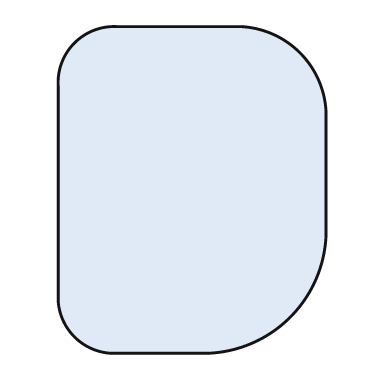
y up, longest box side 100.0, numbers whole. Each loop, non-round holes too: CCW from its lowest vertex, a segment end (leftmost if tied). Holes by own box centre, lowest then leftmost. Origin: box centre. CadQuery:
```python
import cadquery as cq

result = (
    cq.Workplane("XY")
    .moveTo(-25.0, -50.0)
    .lineTo(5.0, -50.0)
    .threePointArc((30.0, -39.0), (41.0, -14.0))
    .lineTo(41.0, 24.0)
    .threePointArc((33.0, 42.0), (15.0, 50.0))
    .lineTo(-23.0, 50.0)
    .threePointArc((-36.0, 45.0), (-41.0, 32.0))
    .lineTo(-41.0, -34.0)
    .threePointArc((-36.0, -45.0), (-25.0, -50.0))
    .close()
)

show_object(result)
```